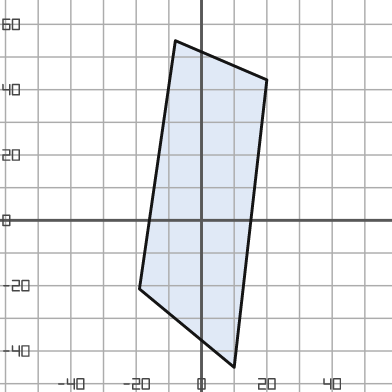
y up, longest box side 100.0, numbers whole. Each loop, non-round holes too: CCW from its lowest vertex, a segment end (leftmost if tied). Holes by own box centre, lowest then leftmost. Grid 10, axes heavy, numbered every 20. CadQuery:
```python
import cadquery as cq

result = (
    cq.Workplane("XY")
    .moveTo(10.0, -45.0)
    .lineTo(20.0, 43.0)
    .lineTo(-8.0, 55.0)
    .lineTo(-19.0, -21.0)
    .close()
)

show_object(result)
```